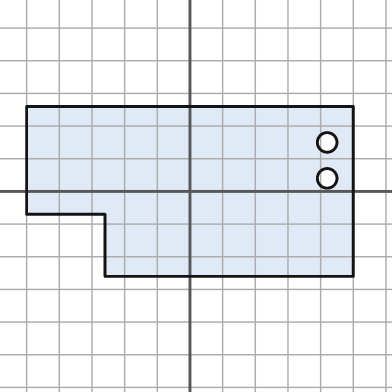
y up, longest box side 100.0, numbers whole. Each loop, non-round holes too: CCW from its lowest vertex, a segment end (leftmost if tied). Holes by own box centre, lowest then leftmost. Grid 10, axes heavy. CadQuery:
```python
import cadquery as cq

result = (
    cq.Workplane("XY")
    .moveTo(-26.0, -26.0)
    .lineTo(50.0, -26.0)
    .lineTo(50.0, 26.0)
    .lineTo(-50.0, 26.0)
    .lineTo(-50.0, -7.0)
    .lineTo(-26.0, -7.0)
    .close()
    .moveTo(42.0, 4.0)
    .circle(3.0)
    .moveTo(42.0, 15.0)
    .circle(3.0)
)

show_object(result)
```